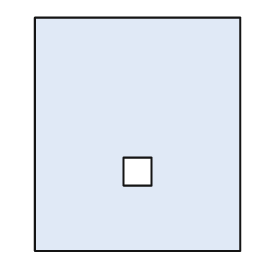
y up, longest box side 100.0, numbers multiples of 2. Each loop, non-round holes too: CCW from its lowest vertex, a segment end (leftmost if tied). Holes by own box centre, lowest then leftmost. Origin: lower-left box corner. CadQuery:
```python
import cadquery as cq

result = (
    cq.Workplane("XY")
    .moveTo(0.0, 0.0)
    .lineTo(88.0, 0.0)
    .lineTo(88.0, 100.0)
    .lineTo(0.0, 100.0)
    .close()
    .moveTo(38.0, 28.0)
    .lineTo(50.0, 28.0)
    .lineTo(50.0, 40.0)
    .lineTo(38.0, 40.0)
    .close()
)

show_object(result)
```